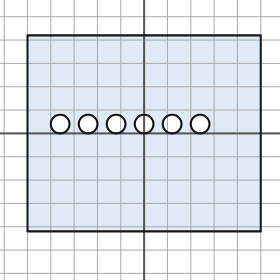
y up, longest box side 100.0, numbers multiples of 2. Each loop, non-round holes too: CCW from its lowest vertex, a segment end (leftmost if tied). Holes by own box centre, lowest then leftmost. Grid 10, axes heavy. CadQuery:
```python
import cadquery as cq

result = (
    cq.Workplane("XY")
    .moveTo(-50.0, -42.0)
    .lineTo(50.0, -42.0)
    .lineTo(50.0, 42.0)
    .lineTo(-50.0, 42.0)
    .close()
    .moveTo(-36.0, 4.0)
    .circle(4.0)
    .moveTo(-24.0, 4.0)
    .circle(4.0)
    .moveTo(-12.0, 4.0)
    .circle(4.0)
    .moveTo(0.0, 4.0)
    .circle(4.0)
    .moveTo(12.0, 4.0)
    .circle(4.0)
    .moveTo(24.0, 4.0)
    .circle(4.0)
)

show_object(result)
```